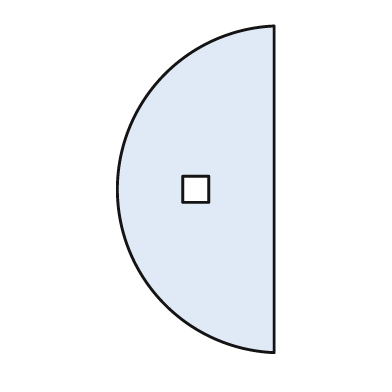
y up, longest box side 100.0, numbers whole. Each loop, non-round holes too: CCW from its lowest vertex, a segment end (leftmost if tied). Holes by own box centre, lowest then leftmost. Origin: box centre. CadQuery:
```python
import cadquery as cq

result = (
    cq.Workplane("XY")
    .moveTo(24.0, -50.0)
    .lineTo(24.0, 50.0)
    .threePointArc((-24.0, 0.0), (24.0, -50.0))
    .close()
    .moveTo(-4.0, -4.0)
    .lineTo(4.0, -4.0)
    .lineTo(4.0, 4.0)
    .lineTo(-4.0, 4.0)
    .close()
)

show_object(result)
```